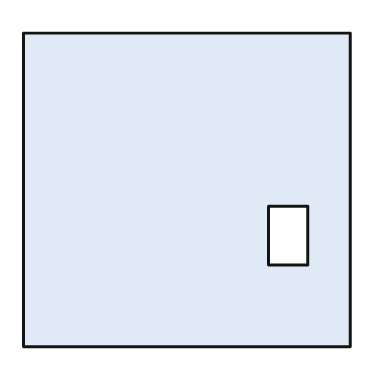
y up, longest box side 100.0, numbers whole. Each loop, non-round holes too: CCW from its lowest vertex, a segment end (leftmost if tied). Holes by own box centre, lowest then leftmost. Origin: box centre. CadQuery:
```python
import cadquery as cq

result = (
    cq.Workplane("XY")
    .moveTo(-50.0, -48.0)
    .lineTo(50.0, -48.0)
    .lineTo(50.0, 48.0)
    .lineTo(-50.0, 48.0)
    .close()
    .moveTo(25.0, -23.0)
    .lineTo(37.0, -23.0)
    .lineTo(37.0, -5.0)
    .lineTo(25.0, -5.0)
    .close()
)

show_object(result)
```